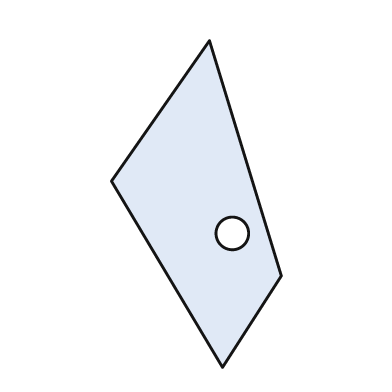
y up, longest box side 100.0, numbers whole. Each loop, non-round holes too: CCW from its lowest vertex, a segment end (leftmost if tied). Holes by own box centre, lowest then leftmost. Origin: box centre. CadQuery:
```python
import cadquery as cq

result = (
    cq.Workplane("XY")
    .moveTo(8.0, -50.0)
    .lineTo(26.0, -22.0)
    .lineTo(4.0, 50.0)
    .lineTo(-26.0, 7.0)
    .close()
    .moveTo(11.0, -9.0)
    .circle(5.0)
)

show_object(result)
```